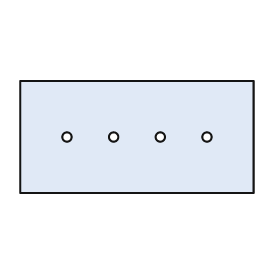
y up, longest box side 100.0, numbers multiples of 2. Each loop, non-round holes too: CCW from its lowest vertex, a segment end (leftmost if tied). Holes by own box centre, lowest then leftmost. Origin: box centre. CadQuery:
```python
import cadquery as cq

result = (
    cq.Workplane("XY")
    .moveTo(-50.0, -24.0)
    .lineTo(50.0, -24.0)
    .lineTo(50.0, 24.0)
    .lineTo(-50.0, 24.0)
    .close()
    .moveTo(-30.0, 0.0)
    .circle(2.0)
    .moveTo(-10.0, 0.0)
    .circle(2.0)
    .moveTo(10.0, 0.0)
    .circle(2.0)
    .moveTo(30.0, 0.0)
    .circle(2.0)
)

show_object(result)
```